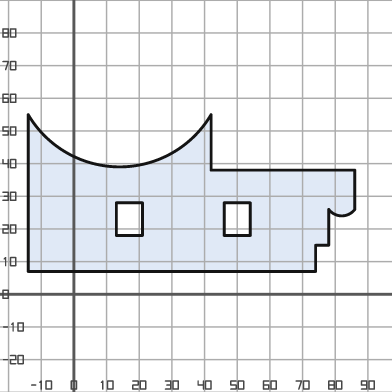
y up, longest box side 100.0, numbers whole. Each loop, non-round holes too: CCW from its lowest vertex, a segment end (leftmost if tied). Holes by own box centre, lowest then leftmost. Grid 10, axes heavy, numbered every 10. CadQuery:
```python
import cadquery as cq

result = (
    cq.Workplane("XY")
    .moveTo(-14.0, 7.0)
    .lineTo(74.0, 7.0)
    .lineTo(74.0, 15.0)
    .lineTo(78.0, 15.0)
    .lineTo(78.0, 26.0)
    .threePointArc((82.0, 24.0), (86.0, 26.0))
    .lineTo(86.0, 38.0)
    .lineTo(42.0, 38.0)
    .lineTo(42.0, 55.0)
    .threePointArc((14.0, 39.0), (-14.0, 55.0))
    .close()
    .moveTo(13.0, 18.0)
    .lineTo(21.0, 18.0)
    .lineTo(21.0, 28.0)
    .lineTo(13.0, 28.0)
    .close()
    .moveTo(46.0, 18.0)
    .lineTo(54.0, 18.0)
    .lineTo(54.0, 28.0)
    .lineTo(46.0, 28.0)
    .close()
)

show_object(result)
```